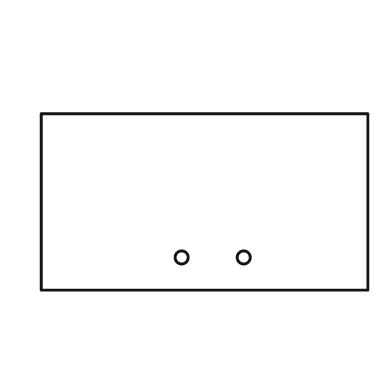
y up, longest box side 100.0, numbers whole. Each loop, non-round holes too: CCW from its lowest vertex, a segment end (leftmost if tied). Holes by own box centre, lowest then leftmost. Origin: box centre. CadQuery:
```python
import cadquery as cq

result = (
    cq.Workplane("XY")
    .moveTo(-50.0, -27.0)
    .lineTo(50.0, -27.0)
    .lineTo(50.0, 27.0)
    .lineTo(-50.0, 27.0)
    .close()
    .moveTo(-7.0, -17.0)
    .circle(2.0)
    .moveTo(12.0, -17.0)
    .circle(2.0)
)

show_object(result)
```